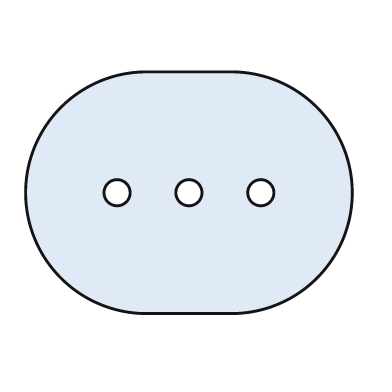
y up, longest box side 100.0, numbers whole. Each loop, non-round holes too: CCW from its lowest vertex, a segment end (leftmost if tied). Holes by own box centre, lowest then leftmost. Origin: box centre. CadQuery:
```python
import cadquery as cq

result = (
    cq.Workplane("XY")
    .moveTo(-13.0, -37.0)
    .lineTo(13.0, -37.0)
    .threePointArc((50.0, 0.0), (13.0, 37.0))
    .lineTo(-13.0, 37.0)
    .threePointArc((-50.0, 0.0), (-13.0, -37.0))
    .close()
    .moveTo(-22.0, 0.0)
    .circle(4.0)
    .moveTo(0.0, 0.0)
    .circle(4.0)
    .moveTo(22.0, 0.0)
    .circle(4.0)
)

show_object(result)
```